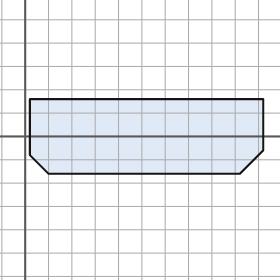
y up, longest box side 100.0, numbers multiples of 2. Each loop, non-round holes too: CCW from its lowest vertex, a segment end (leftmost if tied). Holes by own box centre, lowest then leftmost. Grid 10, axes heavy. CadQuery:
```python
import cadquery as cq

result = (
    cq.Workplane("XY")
    .moveTo(10.0, -16.0)
    .lineTo(92.0, -16.0)
    .lineTo(102.0, -6.0)
    .lineTo(102.0, 16.0)
    .lineTo(2.0, 16.0)
    .lineTo(2.0, -8.0)
    .close()
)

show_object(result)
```